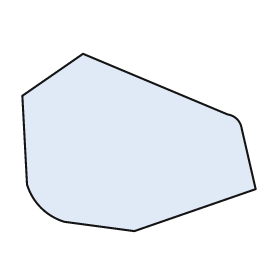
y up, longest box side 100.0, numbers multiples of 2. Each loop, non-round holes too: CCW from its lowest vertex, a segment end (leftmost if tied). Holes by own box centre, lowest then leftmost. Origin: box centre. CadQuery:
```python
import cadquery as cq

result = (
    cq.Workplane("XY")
    .moveTo(-2.0, -38.0)
    .lineTo(50.0, -20.0)
    .lineTo(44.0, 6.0)
    .threePointArc((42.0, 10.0), (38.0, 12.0))
    .lineTo(-24.0, 38.0)
    .lineTo(-50.0, 20.0)
    .lineTo(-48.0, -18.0)
    .threePointArc((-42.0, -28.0), (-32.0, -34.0))
    .close()
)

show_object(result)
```